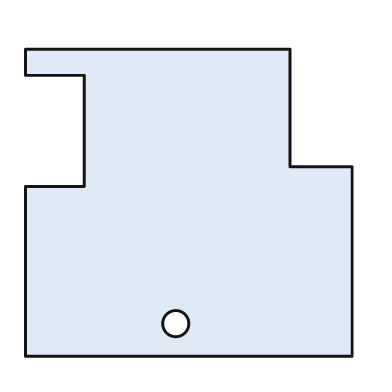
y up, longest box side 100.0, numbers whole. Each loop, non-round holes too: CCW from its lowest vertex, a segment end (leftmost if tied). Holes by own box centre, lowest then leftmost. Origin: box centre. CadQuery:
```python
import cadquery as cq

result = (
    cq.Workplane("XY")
    .moveTo(-50.0, -47.0)
    .lineTo(50.0, -47.0)
    .lineTo(50.0, 11.0)
    .lineTo(31.0, 11.0)
    .lineTo(31.0, 47.0)
    .lineTo(-50.0, 47.0)
    .lineTo(-50.0, 39.0)
    .lineTo(-32.0, 39.0)
    .lineTo(-32.0, 5.0)
    .lineTo(-50.0, 5.0)
    .close()
    .moveTo(-4.0, -37.0)
    .circle(4.0)
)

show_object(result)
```